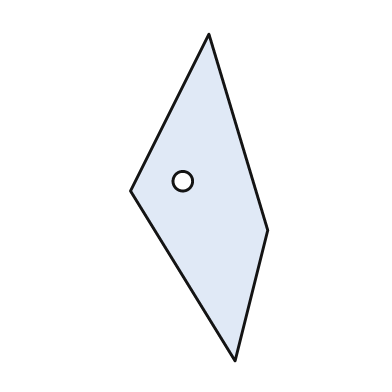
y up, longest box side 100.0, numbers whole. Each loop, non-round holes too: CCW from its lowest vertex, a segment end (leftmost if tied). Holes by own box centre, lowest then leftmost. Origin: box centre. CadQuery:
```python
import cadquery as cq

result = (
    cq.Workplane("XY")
    .moveTo(11.0, -50.0)
    .lineTo(21.0, -10.0)
    .lineTo(3.0, 50.0)
    .lineTo(-21.0, 2.0)
    .close()
    .moveTo(-5.0, 5.0)
    .circle(3.0)
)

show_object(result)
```